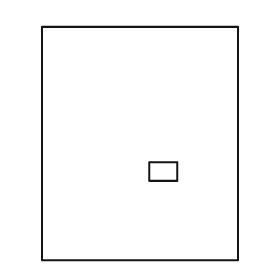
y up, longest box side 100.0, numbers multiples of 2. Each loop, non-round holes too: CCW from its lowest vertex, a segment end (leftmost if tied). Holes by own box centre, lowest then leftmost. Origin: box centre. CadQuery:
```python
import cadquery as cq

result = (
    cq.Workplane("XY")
    .moveTo(-42.0, -50.0)
    .lineTo(42.0, -50.0)
    .lineTo(42.0, 50.0)
    .lineTo(-42.0, 50.0)
    .close()
    .moveTo(4.0, -16.0)
    .lineTo(16.0, -16.0)
    .lineTo(16.0, -8.0)
    .lineTo(4.0, -8.0)
    .close()
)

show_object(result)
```